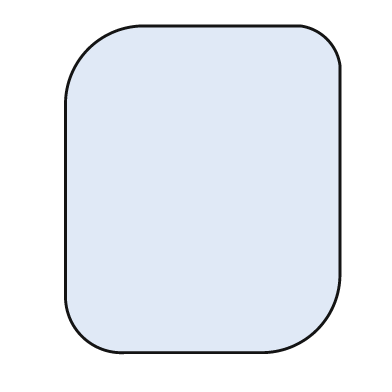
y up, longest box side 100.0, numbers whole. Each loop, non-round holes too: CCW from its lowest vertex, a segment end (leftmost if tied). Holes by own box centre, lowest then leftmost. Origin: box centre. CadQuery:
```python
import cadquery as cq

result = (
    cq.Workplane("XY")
    .moveTo(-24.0, -50.0)
    .lineTo(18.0, -50.0)
    .threePointArc((35.0, -43.0), (42.0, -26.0))
    .lineTo(42.0, 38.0)
    .threePointArc((38.0, 46.0), (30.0, 50.0))
    .lineTo(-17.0, 50.0)
    .threePointArc((-35.0, 43.0), (-42.0, 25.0))
    .lineTo(-42.0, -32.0)
    .threePointArc((-37.0, -45.0), (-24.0, -50.0))
    .close()
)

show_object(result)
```